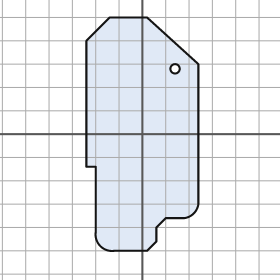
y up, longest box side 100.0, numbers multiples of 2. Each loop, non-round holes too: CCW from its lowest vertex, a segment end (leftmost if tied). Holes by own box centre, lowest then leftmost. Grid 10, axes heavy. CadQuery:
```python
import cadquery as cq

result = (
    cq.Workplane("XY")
    .moveTo(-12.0, -50.0)
    .lineTo(2.0, -50.0)
    .lineTo(6.0, -46.0)
    .lineTo(6.0, -40.0)
    .lineTo(10.0, -36.0)
    .lineTo(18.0, -36.0)
    .threePointArc((22.0, -34.0), (24.0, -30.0))
    .lineTo(24.0, 30.0)
    .lineTo(2.0, 50.0)
    .lineTo(-14.0, 50.0)
    .lineTo(-24.0, 40.0)
    .lineTo(-24.0, -14.0)
    .lineTo(-20.0, -14.0)
    .lineTo(-20.0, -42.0)
    .threePointArc((-18.0, -48.0), (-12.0, -50.0))
    .close()
    .moveTo(14.0, 28.0)
    .circle(2.0)
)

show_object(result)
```